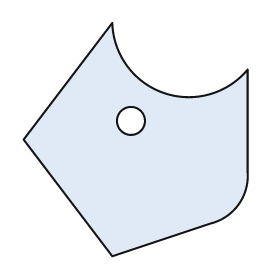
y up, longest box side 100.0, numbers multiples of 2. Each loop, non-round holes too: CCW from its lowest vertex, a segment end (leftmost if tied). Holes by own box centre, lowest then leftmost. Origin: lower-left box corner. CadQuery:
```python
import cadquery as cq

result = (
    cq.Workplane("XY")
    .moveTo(38.0, 0.0)
    .lineTo(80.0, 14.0)
    .threePointArc((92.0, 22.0), (96.0, 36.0))
    .lineTo(96.0, 80.0)
    .threePointArc((60.0, 70.0), (38.0, 100.0))
    .lineTo(0.0, 50.0)
    .close()
    .moveTo(46.0, 58.0)
    .circle(6.0)
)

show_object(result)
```